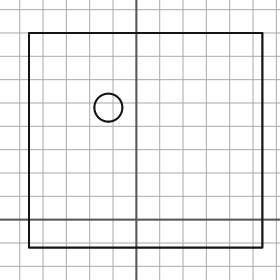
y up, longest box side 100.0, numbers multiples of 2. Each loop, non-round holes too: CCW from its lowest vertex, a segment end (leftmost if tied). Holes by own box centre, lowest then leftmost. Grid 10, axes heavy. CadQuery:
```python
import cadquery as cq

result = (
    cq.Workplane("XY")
    .moveTo(-46.0, -12.0)
    .lineTo(54.0, -12.0)
    .lineTo(54.0, 80.0)
    .lineTo(-46.0, 80.0)
    .close()
    .moveTo(-12.0, 48.0)
    .circle(6.0)
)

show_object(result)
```